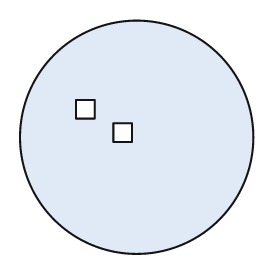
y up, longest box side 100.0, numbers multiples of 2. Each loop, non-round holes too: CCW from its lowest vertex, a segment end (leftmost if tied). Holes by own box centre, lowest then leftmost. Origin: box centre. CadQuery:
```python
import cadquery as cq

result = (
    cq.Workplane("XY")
    .moveTo(0.0, 0.0)
    .circle(50.0)
    .moveTo(-10.0, -2.0)
    .lineTo(-2.0, -2.0)
    .lineTo(-2.0, 6.0)
    .lineTo(-10.0, 6.0)
    .close()
    .moveTo(-26.0, 8.0)
    .lineTo(-18.0, 8.0)
    .lineTo(-18.0, 16.0)
    .lineTo(-26.0, 16.0)
    .close()
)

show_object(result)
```